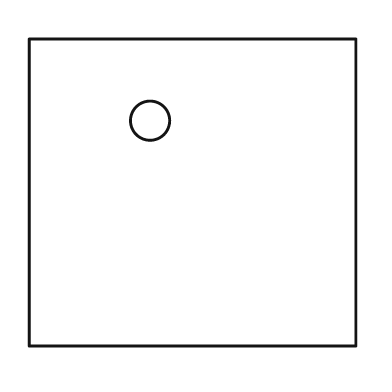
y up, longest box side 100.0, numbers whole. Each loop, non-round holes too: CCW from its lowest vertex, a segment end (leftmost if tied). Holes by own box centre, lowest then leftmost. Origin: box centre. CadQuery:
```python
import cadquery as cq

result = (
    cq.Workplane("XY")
    .moveTo(-50.0, -47.0)
    .lineTo(50.0, -47.0)
    .lineTo(50.0, 47.0)
    .lineTo(-50.0, 47.0)
    .close()
    .moveTo(-13.0, 22.0)
    .circle(6.0)
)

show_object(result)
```